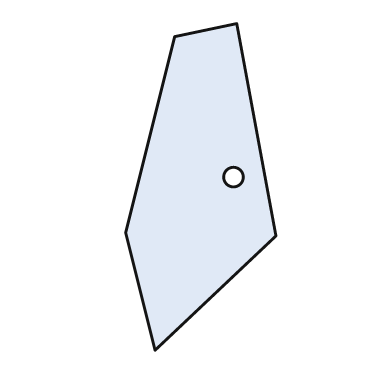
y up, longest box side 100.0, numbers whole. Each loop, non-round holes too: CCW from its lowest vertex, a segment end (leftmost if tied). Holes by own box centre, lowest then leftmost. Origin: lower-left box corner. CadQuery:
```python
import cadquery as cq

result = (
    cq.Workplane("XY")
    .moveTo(9.0, 0.0)
    .lineTo(46.0, 35.0)
    .lineTo(34.0, 100.0)
    .lineTo(15.0, 96.0)
    .lineTo(0.0, 36.0)
    .close()
    .moveTo(33.0, 53.0)
    .circle(3.0)
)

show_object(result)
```